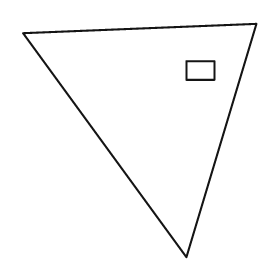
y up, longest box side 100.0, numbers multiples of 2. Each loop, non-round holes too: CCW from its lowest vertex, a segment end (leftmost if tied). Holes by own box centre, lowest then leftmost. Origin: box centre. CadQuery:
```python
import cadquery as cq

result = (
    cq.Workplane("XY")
    .moveTo(20.0, -50.0)
    .lineTo(50.0, 50.0)
    .lineTo(-50.0, 46.0)
    .close()
    .moveTo(20.0, 26.0)
    .lineTo(32.0, 26.0)
    .lineTo(32.0, 34.0)
    .lineTo(20.0, 34.0)
    .close()
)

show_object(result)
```